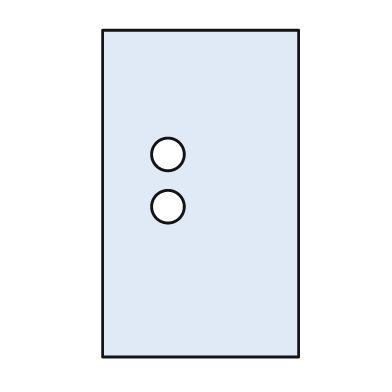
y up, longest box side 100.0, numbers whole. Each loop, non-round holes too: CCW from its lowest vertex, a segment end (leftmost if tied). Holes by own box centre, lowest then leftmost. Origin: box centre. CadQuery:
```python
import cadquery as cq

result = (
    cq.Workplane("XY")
    .moveTo(-30.0, -50.0)
    .lineTo(30.0, -50.0)
    .lineTo(30.0, 50.0)
    .lineTo(-30.0, 50.0)
    .close()
    .moveTo(-10.0, -4.0)
    .circle(5.0)
    .moveTo(-10.0, 12.0)
    .circle(5.0)
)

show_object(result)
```